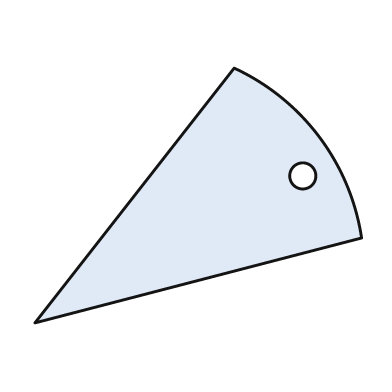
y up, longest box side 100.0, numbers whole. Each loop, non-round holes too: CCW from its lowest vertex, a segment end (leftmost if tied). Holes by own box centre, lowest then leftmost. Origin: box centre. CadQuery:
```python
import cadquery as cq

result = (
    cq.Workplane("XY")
    .moveTo(-50.0, -39.0)
    .lineTo(50.0, -13.0)
    .threePointArc((37.0, 18.0), (11.0, 39.0))
    .close()
    .moveTo(32.0, 6.0)
    .circle(4.0)
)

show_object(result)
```